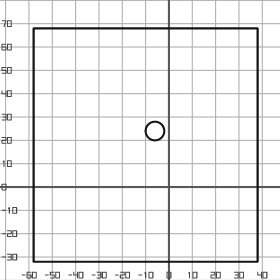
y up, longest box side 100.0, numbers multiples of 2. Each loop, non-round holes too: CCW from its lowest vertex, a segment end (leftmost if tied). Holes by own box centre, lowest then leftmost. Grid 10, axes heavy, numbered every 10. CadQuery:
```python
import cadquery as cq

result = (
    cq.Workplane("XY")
    .moveTo(-58.0, -32.0)
    .lineTo(38.0, -32.0)
    .lineTo(38.0, 68.0)
    .lineTo(-58.0, 68.0)
    .close()
    .moveTo(-6.0, 24.0)
    .circle(4.0)
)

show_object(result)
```